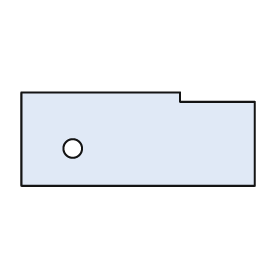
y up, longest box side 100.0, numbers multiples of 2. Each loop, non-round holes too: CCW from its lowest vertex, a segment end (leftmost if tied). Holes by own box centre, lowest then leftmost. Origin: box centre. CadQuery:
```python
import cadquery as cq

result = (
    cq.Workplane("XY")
    .moveTo(-50.0, -20.0)
    .lineTo(50.0, -20.0)
    .lineTo(50.0, 16.0)
    .lineTo(18.0, 16.0)
    .lineTo(18.0, 20.0)
    .lineTo(-50.0, 20.0)
    .close()
    .moveTo(-28.0, -4.0)
    .circle(4.0)
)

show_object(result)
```